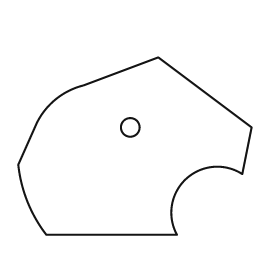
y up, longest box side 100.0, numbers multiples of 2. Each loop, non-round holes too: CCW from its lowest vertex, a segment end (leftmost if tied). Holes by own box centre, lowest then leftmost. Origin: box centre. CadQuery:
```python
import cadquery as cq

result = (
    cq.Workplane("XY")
    .moveTo(-38.0, -38.0)
    .lineTo(18.0, -38.0)
    .threePointArc((22.0, -14.0), (46.0, -12.0))
    .lineTo(50.0, 8.0)
    .lineTo(10.0, 38.0)
    .lineTo(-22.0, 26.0)
    .threePointArc((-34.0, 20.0), (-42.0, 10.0))
    .lineTo(-50.0, -8.0)
    .threePointArc((-46.0, -24.0), (-38.0, -38.0))
    .close()
    .moveTo(-2.0, 8.0)
    .circle(4.0)
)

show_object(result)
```